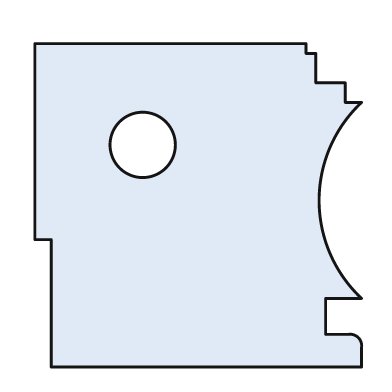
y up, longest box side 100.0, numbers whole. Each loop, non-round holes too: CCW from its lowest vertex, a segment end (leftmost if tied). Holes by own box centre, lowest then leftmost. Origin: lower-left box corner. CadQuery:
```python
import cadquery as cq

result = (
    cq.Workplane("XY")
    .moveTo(5.0, 0.0)
    .lineTo(100.0, 0.0)
    .lineTo(100.0, 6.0)
    .threePointArc((99.0, 9.0), (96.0, 10.0))
    .lineTo(89.0, 10.0)
    .lineTo(89.0, 21.0)
    .lineTo(100.0, 21.0)
    .threePointArc((87.0, 51.0), (100.0, 81.0))
    .lineTo(95.0, 81.0)
    .lineTo(95.0, 87.0)
    .lineTo(86.0, 87.0)
    .lineTo(86.0, 96.0)
    .lineTo(83.0, 96.0)
    .lineTo(83.0, 99.0)
    .lineTo(0.0, 99.0)
    .lineTo(0.0, 39.0)
    .lineTo(5.0, 39.0)
    .close()
    .moveTo(33.0, 68.0)
    .circle(10.0)
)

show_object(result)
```